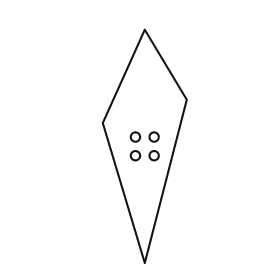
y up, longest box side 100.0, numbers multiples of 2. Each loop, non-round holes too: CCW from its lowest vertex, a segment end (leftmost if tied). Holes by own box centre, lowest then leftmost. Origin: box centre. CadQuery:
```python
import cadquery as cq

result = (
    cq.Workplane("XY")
    .moveTo(0.0, -50.0)
    .lineTo(18.0, 20.0)
    .lineTo(0.0, 50.0)
    .lineTo(-18.0, 10.0)
    .close()
    .moveTo(-4.0, -4.0)
    .circle(2.0)
    .moveTo(4.0, -4.0)
    .circle(2.0)
    .moveTo(-4.0, 4.0)
    .circle(2.0)
    .moveTo(4.0, 4.0)
    .circle(2.0)
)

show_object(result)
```